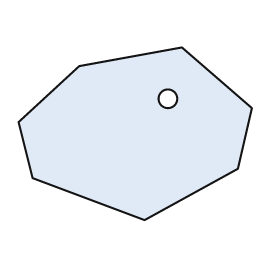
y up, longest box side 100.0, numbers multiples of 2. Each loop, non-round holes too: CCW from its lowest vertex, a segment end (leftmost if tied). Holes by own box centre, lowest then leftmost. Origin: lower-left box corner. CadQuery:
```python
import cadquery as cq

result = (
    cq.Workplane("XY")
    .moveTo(54.0, 0.0)
    .lineTo(94.0, 22.0)
    .lineTo(100.0, 48.0)
    .lineTo(70.0, 74.0)
    .lineTo(26.0, 66.0)
    .lineTo(0.0, 42.0)
    .lineTo(6.0, 18.0)
    .close()
    .moveTo(64.0, 52.0)
    .circle(4.0)
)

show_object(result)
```